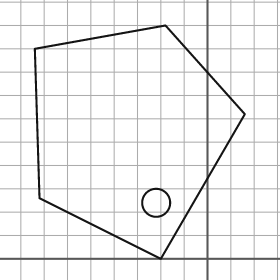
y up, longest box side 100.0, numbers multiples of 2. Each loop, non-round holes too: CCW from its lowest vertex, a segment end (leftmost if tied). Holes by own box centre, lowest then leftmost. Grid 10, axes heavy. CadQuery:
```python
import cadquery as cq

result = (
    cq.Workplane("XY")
    .moveTo(-20.0, 0.0)
    .lineTo(16.0, 62.0)
    .lineTo(-18.0, 100.0)
    .lineTo(-74.0, 90.0)
    .lineTo(-72.0, 26.0)
    .close()
    .moveTo(-22.0, 24.0)
    .circle(6.0)
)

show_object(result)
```